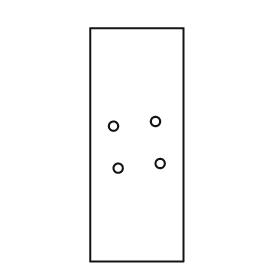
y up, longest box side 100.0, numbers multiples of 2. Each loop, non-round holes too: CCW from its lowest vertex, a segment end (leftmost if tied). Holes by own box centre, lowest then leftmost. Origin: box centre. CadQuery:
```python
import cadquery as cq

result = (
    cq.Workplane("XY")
    .moveTo(-20.0, -50.0)
    .lineTo(20.0, -50.0)
    .lineTo(20.0, 50.0)
    .lineTo(-20.0, 50.0)
    .close()
    .moveTo(-8.0, -10.0)
    .circle(2.0)
    .moveTo(10.0, -8.0)
    .circle(2.0)
    .moveTo(-10.0, 8.0)
    .circle(2.0)
    .moveTo(8.0, 10.0)
    .circle(2.0)
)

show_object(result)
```